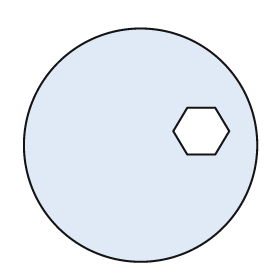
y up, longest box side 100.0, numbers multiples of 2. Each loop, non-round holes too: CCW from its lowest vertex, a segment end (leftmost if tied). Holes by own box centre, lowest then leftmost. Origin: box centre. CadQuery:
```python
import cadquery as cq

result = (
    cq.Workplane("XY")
    .moveTo(0.0, 0.0)
    .circle(50.0)
    .moveTo(20.0, -4.0)
    .lineTo(32.0, -4.0)
    .lineTo(38.0, 6.0)
    .lineTo(32.0, 16.0)
    .lineTo(20.0, 16.0)
    .lineTo(14.0, 6.0)
    .close()
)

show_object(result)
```